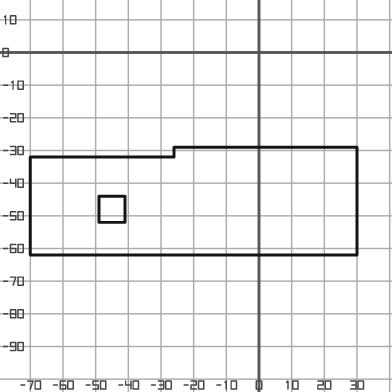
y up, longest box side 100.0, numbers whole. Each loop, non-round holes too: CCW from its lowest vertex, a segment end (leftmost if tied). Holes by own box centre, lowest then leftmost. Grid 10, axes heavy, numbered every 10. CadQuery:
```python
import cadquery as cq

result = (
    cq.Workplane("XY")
    .moveTo(-70.0, -62.0)
    .lineTo(30.0, -62.0)
    .lineTo(30.0, -29.0)
    .lineTo(-26.0, -29.0)
    .lineTo(-26.0, -32.0)
    .lineTo(-70.0, -32.0)
    .close()
    .moveTo(-49.0, -52.0)
    .lineTo(-41.0, -52.0)
    .lineTo(-41.0, -44.0)
    .lineTo(-49.0, -44.0)
    .close()
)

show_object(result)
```